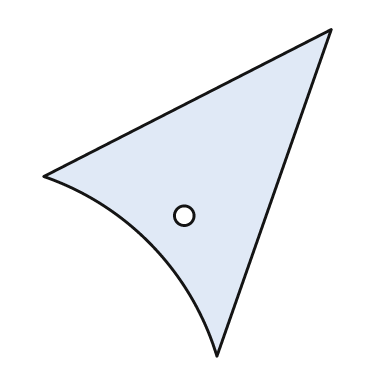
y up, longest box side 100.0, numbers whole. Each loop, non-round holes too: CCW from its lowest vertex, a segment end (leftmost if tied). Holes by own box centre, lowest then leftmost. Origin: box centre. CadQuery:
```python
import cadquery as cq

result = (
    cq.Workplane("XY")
    .moveTo(9.0, -50.0)
    .lineTo(44.0, 50.0)
    .lineTo(-44.0, 5.0)
    .threePointArc((-11.0, -16.0), (9.0, -50.0))
    .close()
    .moveTo(-1.0, -7.0)
    .circle(3.0)
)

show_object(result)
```